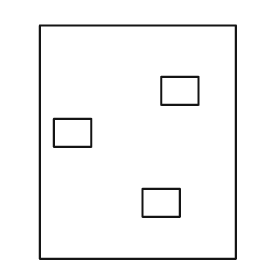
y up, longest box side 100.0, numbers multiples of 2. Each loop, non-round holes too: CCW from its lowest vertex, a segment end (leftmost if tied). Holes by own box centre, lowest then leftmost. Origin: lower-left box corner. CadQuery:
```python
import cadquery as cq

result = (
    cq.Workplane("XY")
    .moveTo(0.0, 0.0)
    .lineTo(84.0, 0.0)
    .lineTo(84.0, 100.0)
    .lineTo(0.0, 100.0)
    .close()
    .moveTo(44.0, 18.0)
    .lineTo(60.0, 18.0)
    .lineTo(60.0, 30.0)
    .lineTo(44.0, 30.0)
    .close()
    .moveTo(6.0, 48.0)
    .lineTo(22.0, 48.0)
    .lineTo(22.0, 60.0)
    .lineTo(6.0, 60.0)
    .close()
    .moveTo(52.0, 66.0)
    .lineTo(68.0, 66.0)
    .lineTo(68.0, 78.0)
    .lineTo(52.0, 78.0)
    .close()
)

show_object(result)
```